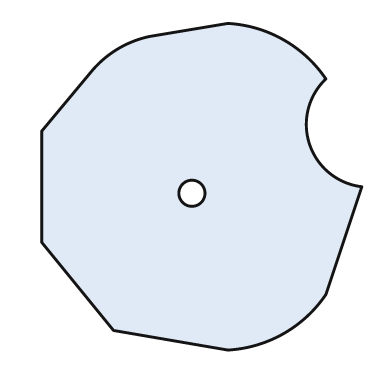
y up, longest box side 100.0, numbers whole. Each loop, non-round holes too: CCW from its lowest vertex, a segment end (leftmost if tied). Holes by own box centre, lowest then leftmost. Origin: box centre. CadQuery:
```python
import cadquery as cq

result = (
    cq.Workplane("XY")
    .moveTo(8.0, -50.0)
    .threePointArc((25.0, -45.0), (38.0, -33.0))
    .lineTo(49.0, 0.0)
    .threePointArc((33.0, 13.0), (38.0, 33.0))
    .threePointArc((25.0, 45.0), (8.0, 50.0))
    .lineTo(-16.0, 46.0)
    .threePointArc((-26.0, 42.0), (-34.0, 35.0))
    .lineTo(-49.0, 17.0)
    .lineTo(-49.0, -17.0)
    .lineTo(-27.0, -44.0)
    .close()
    .moveTo(-3.0, -2.0)
    .circle(4.0)
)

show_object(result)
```